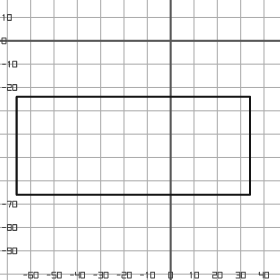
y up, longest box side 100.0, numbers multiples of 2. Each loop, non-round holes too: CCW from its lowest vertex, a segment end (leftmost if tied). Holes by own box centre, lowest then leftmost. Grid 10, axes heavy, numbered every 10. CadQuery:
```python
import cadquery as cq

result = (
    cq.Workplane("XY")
    .moveTo(-66.0, -66.0)
    .lineTo(34.0, -66.0)
    .lineTo(34.0, -24.0)
    .lineTo(-66.0, -24.0)
    .close()
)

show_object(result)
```